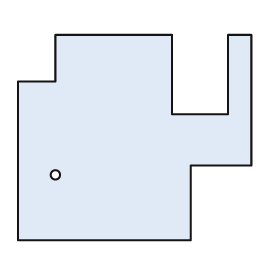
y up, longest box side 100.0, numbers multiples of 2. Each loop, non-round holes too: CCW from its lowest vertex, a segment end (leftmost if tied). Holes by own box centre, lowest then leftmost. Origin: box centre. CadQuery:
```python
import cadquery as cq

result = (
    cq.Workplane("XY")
    .moveTo(-50.0, -44.0)
    .lineTo(24.0, -44.0)
    .lineTo(24.0, -12.0)
    .lineTo(50.0, -12.0)
    .lineTo(50.0, 44.0)
    .lineTo(40.0, 44.0)
    .lineTo(40.0, 10.0)
    .lineTo(16.0, 10.0)
    .lineTo(16.0, 44.0)
    .lineTo(-34.0, 44.0)
    .lineTo(-34.0, 24.0)
    .lineTo(-50.0, 24.0)
    .close()
    .moveTo(-34.0, -16.0)
    .circle(2.0)
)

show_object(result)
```